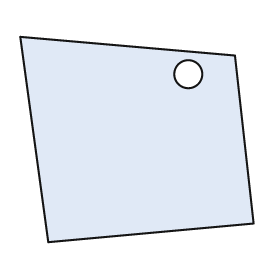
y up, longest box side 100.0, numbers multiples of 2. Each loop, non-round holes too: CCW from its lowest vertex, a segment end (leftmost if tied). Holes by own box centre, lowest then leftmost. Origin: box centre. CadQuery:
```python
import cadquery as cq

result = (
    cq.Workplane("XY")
    .moveTo(-38.0, -44.0)
    .lineTo(50.0, -36.0)
    .lineTo(42.0, 36.0)
    .lineTo(-50.0, 44.0)
    .close()
    .moveTo(22.0, 28.0)
    .circle(6.0)
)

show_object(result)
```